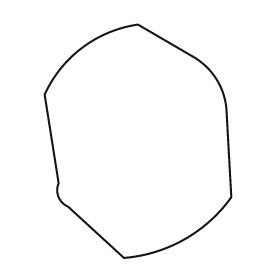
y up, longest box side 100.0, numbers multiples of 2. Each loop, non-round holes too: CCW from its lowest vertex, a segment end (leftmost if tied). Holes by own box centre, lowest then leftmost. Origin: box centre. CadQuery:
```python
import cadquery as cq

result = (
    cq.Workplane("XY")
    .moveTo(-6.0, -50.0)
    .threePointArc((20.0, -42.0), (40.0, -24.0))
    .lineTo(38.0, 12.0)
    .threePointArc((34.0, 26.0), (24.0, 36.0))
    .lineTo(0.0, 50.0)
    .threePointArc((-24.0, 40.0), (-40.0, 20.0))
    .lineTo(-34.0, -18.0)
    .threePointArc((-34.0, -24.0), (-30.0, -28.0))
    .close()
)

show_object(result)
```